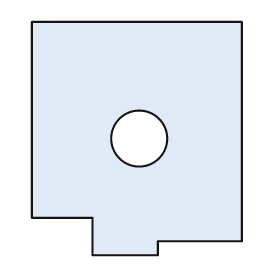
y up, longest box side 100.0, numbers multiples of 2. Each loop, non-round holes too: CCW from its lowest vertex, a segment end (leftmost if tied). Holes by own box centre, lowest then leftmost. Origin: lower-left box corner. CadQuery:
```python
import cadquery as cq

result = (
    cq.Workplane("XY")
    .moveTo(26.0, 0.0)
    .lineTo(54.0, 0.0)
    .lineTo(54.0, 6.0)
    .lineTo(90.0, 6.0)
    .lineTo(90.0, 100.0)
    .lineTo(0.0, 100.0)
    .lineTo(0.0, 16.0)
    .lineTo(26.0, 16.0)
    .close()
    .moveTo(46.0, 50.0)
    .circle(12.0)
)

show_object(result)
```